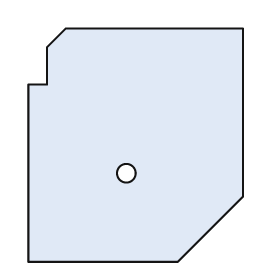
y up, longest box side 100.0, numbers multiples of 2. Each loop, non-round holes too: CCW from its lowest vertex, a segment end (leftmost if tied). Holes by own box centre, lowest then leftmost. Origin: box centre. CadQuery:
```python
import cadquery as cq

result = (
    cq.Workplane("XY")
    .moveTo(-46.0, -50.0)
    .lineTo(18.0, -50.0)
    .lineTo(46.0, -22.0)
    .lineTo(46.0, 50.0)
    .lineTo(-30.0, 50.0)
    .lineTo(-38.0, 42.0)
    .lineTo(-38.0, 26.0)
    .lineTo(-46.0, 26.0)
    .close()
    .moveTo(-4.0, -12.0)
    .circle(4.0)
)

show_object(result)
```